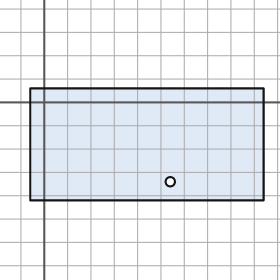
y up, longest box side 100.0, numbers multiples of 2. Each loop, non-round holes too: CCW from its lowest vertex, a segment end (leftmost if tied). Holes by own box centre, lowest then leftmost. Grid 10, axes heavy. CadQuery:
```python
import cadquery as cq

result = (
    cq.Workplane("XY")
    .moveTo(-6.0, -42.0)
    .lineTo(94.0, -42.0)
    .lineTo(94.0, 6.0)
    .lineTo(-6.0, 6.0)
    .close()
    .moveTo(54.0, -34.0)
    .circle(2.0)
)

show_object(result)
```